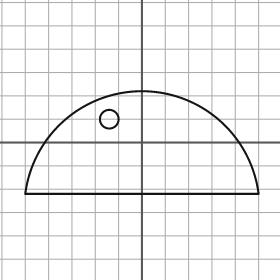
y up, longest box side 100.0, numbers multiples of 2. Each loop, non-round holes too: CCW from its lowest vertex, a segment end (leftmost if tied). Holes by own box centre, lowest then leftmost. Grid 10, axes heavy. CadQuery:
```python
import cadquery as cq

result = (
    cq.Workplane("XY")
    .moveTo(-50.0, -22.0)
    .lineTo(50.0, -22.0)
    .threePointArc((0.0, 22.0), (-50.0, -22.0))
    .close()
    .moveTo(-14.0, 10.0)
    .circle(4.0)
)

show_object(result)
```